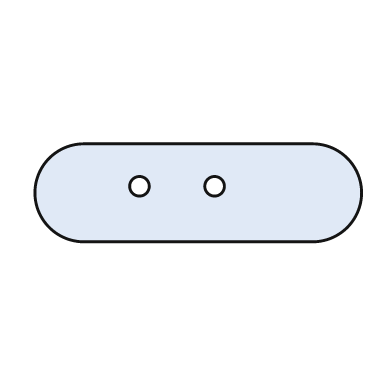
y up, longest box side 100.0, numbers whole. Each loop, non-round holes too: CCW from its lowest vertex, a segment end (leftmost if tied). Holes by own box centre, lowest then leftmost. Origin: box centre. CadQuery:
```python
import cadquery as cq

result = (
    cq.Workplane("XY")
    .moveTo(-35.0, -15.0)
    .lineTo(35.0, -15.0)
    .threePointArc((50.0, 0.0), (35.0, 15.0))
    .lineTo(-35.0, 15.0)
    .threePointArc((-50.0, 0.0), (-35.0, -15.0))
    .close()
    .moveTo(-18.0, 2.0)
    .circle(3.0)
    .moveTo(5.0, 2.0)
    .circle(3.0)
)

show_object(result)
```